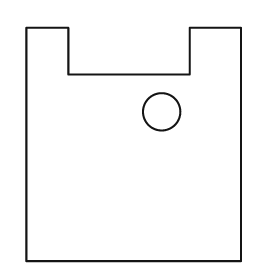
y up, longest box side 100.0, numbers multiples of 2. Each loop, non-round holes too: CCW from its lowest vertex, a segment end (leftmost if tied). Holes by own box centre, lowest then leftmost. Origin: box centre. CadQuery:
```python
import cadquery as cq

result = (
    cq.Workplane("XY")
    .moveTo(-46.0, -50.0)
    .lineTo(46.0, -50.0)
    .lineTo(46.0, 50.0)
    .lineTo(24.0, 50.0)
    .lineTo(24.0, 30.0)
    .lineTo(-28.0, 30.0)
    .lineTo(-28.0, 50.0)
    .lineTo(-46.0, 50.0)
    .close()
    .moveTo(12.0, 14.0)
    .circle(8.0)
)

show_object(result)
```